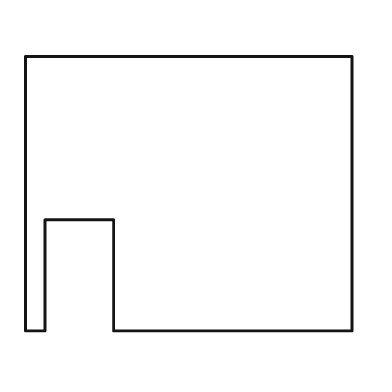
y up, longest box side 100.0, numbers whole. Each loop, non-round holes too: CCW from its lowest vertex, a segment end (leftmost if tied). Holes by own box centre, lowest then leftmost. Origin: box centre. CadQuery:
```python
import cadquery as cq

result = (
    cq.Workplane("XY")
    .moveTo(-50.0, -42.0)
    .lineTo(-44.0, -42.0)
    .lineTo(-44.0, -8.0)
    .lineTo(-23.0, -8.0)
    .lineTo(-23.0, -42.0)
    .lineTo(50.0, -42.0)
    .lineTo(50.0, 42.0)
    .lineTo(-50.0, 42.0)
    .close()
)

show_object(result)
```